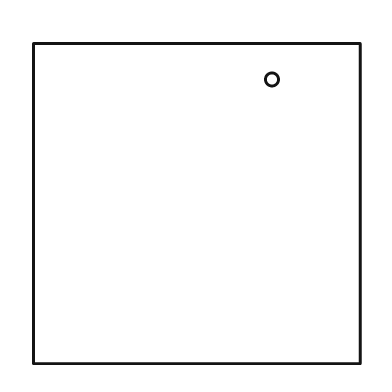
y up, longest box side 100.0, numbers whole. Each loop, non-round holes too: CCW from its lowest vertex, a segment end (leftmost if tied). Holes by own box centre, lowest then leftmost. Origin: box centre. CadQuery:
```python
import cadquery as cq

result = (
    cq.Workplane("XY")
    .moveTo(-50.0, -49.0)
    .lineTo(50.0, -49.0)
    .lineTo(50.0, 49.0)
    .lineTo(-50.0, 49.0)
    .close()
    .moveTo(23.0, 38.0)
    .circle(2.0)
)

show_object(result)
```